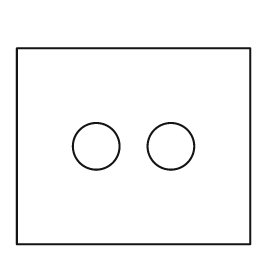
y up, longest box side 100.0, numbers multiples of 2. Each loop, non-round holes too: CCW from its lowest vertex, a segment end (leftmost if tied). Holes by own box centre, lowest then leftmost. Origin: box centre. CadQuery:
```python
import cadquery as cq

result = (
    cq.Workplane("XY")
    .moveTo(-50.0, -42.0)
    .lineTo(50.0, -42.0)
    .lineTo(50.0, 42.0)
    .lineTo(-50.0, 42.0)
    .close()
    .moveTo(-16.0, 0.0)
    .circle(10.0)
    .moveTo(16.0, 0.0)
    .circle(10.0)
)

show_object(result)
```